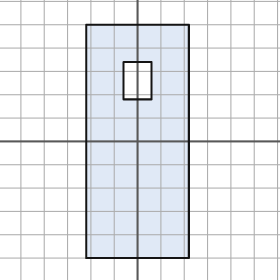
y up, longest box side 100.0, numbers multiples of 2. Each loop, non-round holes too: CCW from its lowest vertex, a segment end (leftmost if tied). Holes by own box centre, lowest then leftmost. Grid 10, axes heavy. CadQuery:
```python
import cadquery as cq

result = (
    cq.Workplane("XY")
    .moveTo(-22.0, -50.0)
    .lineTo(22.0, -50.0)
    .lineTo(22.0, 50.0)
    .lineTo(-22.0, 50.0)
    .close()
    .moveTo(-6.0, 18.0)
    .lineTo(6.0, 18.0)
    .lineTo(6.0, 34.0)
    .lineTo(-6.0, 34.0)
    .close()
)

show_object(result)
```